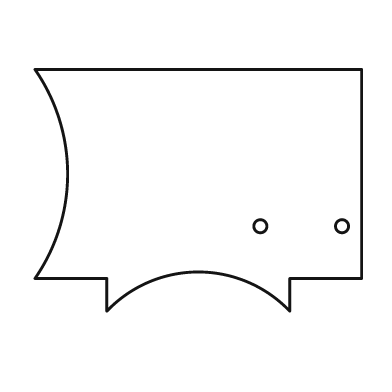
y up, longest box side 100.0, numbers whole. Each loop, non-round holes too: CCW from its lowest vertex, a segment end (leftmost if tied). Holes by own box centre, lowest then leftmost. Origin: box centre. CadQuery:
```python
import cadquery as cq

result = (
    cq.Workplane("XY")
    .moveTo(-28.0, -37.0)
    .threePointArc((0.0, -25.0), (28.0, -37.0))
    .lineTo(28.0, -27.0)
    .lineTo(50.0, -27.0)
    .lineTo(50.0, 37.0)
    .lineTo(-50.0, 37.0)
    .threePointArc((-40.0, 5.0), (-50.0, -27.0))
    .lineTo(-28.0, -27.0)
    .close()
    .moveTo(19.0, -11.0)
    .circle(2.0)
    .moveTo(44.0, -11.0)
    .circle(2.0)
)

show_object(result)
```